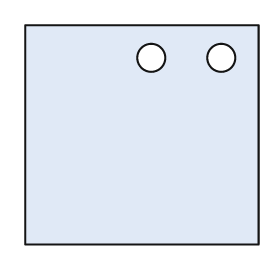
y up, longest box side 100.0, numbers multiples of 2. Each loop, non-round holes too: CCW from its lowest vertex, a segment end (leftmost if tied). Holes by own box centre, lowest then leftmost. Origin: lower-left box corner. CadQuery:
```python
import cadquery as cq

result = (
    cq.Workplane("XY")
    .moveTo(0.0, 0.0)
    .lineTo(100.0, 0.0)
    .lineTo(100.0, 94.0)
    .lineTo(0.0, 94.0)
    .close()
    .moveTo(54.0, 80.0)
    .circle(6.0)
    .moveTo(84.0, 80.0)
    .circle(6.0)
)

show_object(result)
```